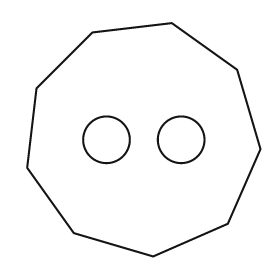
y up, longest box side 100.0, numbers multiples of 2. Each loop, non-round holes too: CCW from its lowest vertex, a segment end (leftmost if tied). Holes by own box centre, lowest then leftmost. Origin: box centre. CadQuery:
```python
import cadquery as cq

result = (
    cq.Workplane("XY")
    .moveTo(4.0, -50.0)
    .lineTo(36.0, -36.0)
    .lineTo(50.0, -4.0)
    .lineTo(40.0, 30.0)
    .lineTo(12.0, 50.0)
    .lineTo(-22.0, 46.0)
    .lineTo(-46.0, 22.0)
    .lineTo(-50.0, -12.0)
    .lineTo(-30.0, -40.0)
    .close()
    .moveTo(-16.0, 0.0)
    .circle(10.0)
    .moveTo(16.0, 0.0)
    .circle(10.0)
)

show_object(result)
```